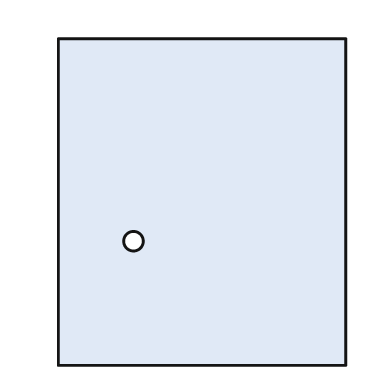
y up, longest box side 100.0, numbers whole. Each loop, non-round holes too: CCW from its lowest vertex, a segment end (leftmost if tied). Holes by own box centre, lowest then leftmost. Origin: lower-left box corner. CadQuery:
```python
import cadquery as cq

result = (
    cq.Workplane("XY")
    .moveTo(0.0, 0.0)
    .lineTo(88.0, 0.0)
    .lineTo(88.0, 100.0)
    .lineTo(0.0, 100.0)
    .close()
    .moveTo(23.0, 38.0)
    .circle(3.0)
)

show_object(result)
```